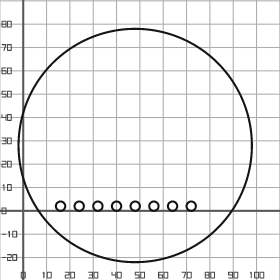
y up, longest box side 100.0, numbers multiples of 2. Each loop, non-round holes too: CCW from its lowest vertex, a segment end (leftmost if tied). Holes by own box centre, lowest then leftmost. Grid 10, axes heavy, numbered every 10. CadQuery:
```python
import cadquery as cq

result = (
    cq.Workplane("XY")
    .moveTo(48.0, 28.0)
    .circle(50.0)
    .moveTo(16.0, 2.0)
    .circle(2.0)
    .moveTo(24.0, 2.0)
    .circle(2.0)
    .moveTo(32.0, 2.0)
    .circle(2.0)
    .moveTo(40.0, 2.0)
    .circle(2.0)
    .moveTo(48.0, 2.0)
    .circle(2.0)
    .moveTo(56.0, 2.0)
    .circle(2.0)
    .moveTo(64.0, 2.0)
    .circle(2.0)
    .moveTo(72.0, 2.0)
    .circle(2.0)
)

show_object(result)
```